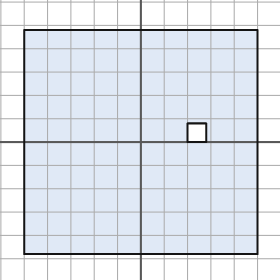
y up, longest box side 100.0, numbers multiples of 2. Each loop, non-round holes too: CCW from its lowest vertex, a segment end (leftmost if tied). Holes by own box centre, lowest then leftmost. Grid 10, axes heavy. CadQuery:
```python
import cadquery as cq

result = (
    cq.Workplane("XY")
    .moveTo(-50.0, -48.0)
    .lineTo(50.0, -48.0)
    .lineTo(50.0, 48.0)
    .lineTo(-50.0, 48.0)
    .close()
    .moveTo(20.0, 0.0)
    .lineTo(28.0, 0.0)
    .lineTo(28.0, 8.0)
    .lineTo(20.0, 8.0)
    .close()
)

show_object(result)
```